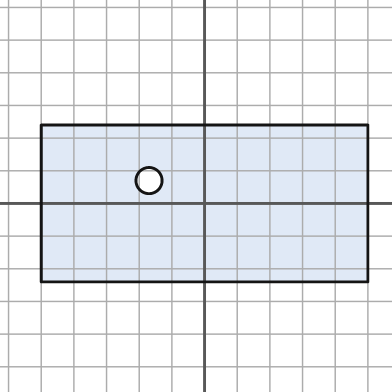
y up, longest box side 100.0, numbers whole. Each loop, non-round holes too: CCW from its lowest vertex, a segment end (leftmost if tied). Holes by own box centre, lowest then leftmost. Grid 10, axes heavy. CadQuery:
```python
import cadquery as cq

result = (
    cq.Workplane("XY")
    .moveTo(-50.0, -24.0)
    .lineTo(50.0, -24.0)
    .lineTo(50.0, 24.0)
    .lineTo(-50.0, 24.0)
    .close()
    .moveTo(-17.0, 7.0)
    .circle(4.0)
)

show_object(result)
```